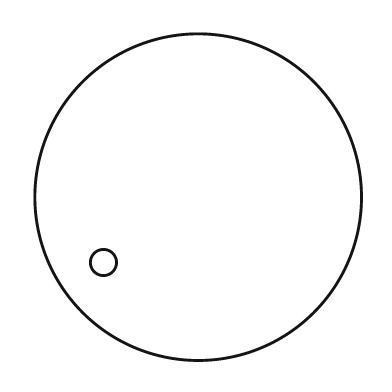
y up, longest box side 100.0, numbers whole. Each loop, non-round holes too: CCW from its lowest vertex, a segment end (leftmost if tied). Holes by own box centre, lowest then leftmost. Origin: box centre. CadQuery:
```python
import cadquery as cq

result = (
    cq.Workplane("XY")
    .moveTo(0.0, 0.0)
    .circle(50.0)
    .moveTo(-29.0, -20.0)
    .circle(4.0)
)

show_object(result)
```